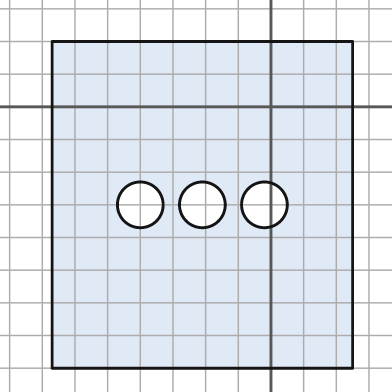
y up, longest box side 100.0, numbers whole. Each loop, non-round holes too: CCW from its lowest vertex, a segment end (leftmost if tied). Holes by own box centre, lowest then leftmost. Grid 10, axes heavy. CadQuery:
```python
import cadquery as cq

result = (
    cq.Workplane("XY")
    .moveTo(-67.0, -80.0)
    .lineTo(25.0, -80.0)
    .lineTo(25.0, 20.0)
    .lineTo(-67.0, 20.0)
    .close()
    .moveTo(-40.0, -30.0)
    .circle(7.0)
    .moveTo(-21.0, -30.0)
    .circle(7.0)
    .moveTo(-2.0, -30.0)
    .circle(7.0)
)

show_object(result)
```